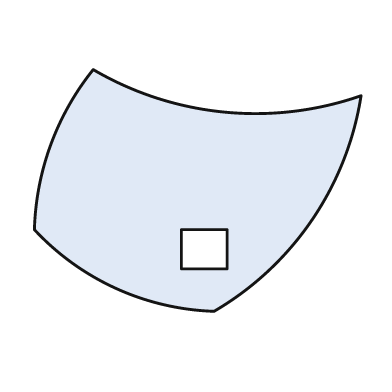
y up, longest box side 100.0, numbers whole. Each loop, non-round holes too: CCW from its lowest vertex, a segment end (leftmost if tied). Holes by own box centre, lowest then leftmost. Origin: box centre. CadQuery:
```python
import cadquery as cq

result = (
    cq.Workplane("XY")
    .moveTo(5.0, -37.0)
    .threePointArc((35.0, -9.0), (50.0, 29.0))
    .threePointArc((8.0, 24.0), (-32.0, 37.0))
    .threePointArc((-45.0, 14.0), (-50.0, -12.0))
    .threePointArc((-25.0, -30.0), (5.0, -37.0))
    .close()
    .moveTo(-5.0, -24.0)
    .lineTo(9.0, -24.0)
    .lineTo(9.0, -12.0)
    .lineTo(-5.0, -12.0)
    .close()
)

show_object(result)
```